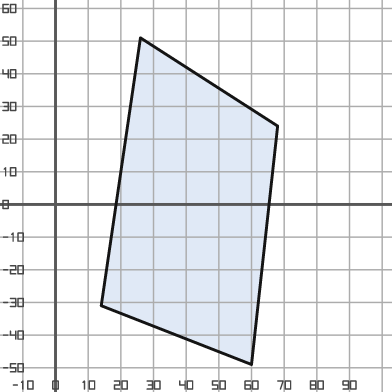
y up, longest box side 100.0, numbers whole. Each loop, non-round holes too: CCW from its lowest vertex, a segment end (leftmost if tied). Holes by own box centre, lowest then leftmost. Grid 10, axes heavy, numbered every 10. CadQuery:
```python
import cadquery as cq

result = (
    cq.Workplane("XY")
    .moveTo(60.0, -49.0)
    .lineTo(68.0, 24.0)
    .lineTo(26.0, 51.0)
    .lineTo(14.0, -31.0)
    .close()
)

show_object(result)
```